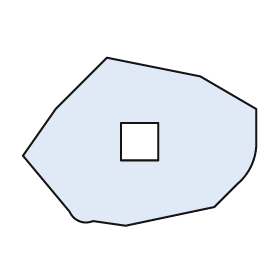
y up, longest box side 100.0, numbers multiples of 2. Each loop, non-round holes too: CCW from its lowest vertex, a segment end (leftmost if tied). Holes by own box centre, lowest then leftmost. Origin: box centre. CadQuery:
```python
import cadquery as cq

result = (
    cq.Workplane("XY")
    .moveTo(-6.0, -36.0)
    .lineTo(32.0, -28.0)
    .lineTo(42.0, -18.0)
    .threePointArc((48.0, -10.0), (50.0, 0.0))
    .lineTo(50.0, 14.0)
    .lineTo(26.0, 28.0)
    .lineTo(-14.0, 36.0)
    .lineTo(-36.0, 14.0)
    .lineTo(-50.0, -6.0)
    .lineTo(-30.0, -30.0)
    .threePointArc((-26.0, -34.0), (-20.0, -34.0))
    .close()
    .moveTo(-8.0, -8.0)
    .lineTo(8.0, -8.0)
    .lineTo(8.0, 8.0)
    .lineTo(-8.0, 8.0)
    .close()
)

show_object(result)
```